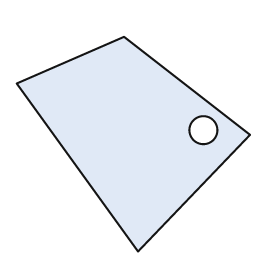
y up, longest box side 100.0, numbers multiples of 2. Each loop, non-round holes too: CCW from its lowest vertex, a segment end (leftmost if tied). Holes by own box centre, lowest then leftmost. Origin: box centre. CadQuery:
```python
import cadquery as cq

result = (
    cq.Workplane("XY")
    .moveTo(2.0, -46.0)
    .lineTo(50.0, 4.0)
    .lineTo(-4.0, 46.0)
    .lineTo(-50.0, 26.0)
    .close()
    .moveTo(30.0, 6.0)
    .circle(6.0)
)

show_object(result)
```